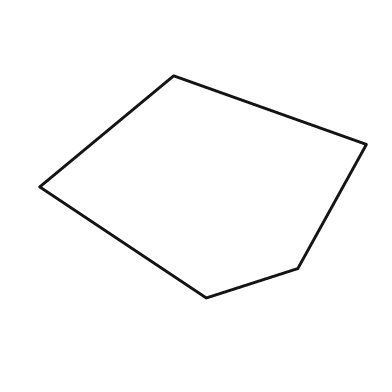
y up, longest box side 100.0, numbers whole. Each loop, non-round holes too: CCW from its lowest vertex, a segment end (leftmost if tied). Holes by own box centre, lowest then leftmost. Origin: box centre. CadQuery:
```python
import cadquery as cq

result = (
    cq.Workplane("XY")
    .moveTo(1.0, -34.0)
    .lineTo(29.0, -25.0)
    .lineTo(50.0, 13.0)
    .lineTo(-9.0, 34.0)
    .lineTo(-50.0, 0.0)
    .close()
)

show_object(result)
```